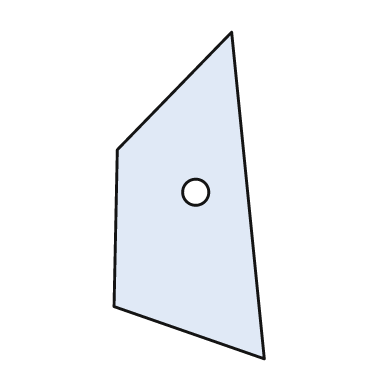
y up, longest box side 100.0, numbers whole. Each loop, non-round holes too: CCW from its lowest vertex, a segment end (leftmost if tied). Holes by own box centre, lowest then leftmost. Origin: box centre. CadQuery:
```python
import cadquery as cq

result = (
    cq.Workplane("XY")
    .moveTo(23.0, -50.0)
    .lineTo(13.0, 50.0)
    .lineTo(-22.0, 14.0)
    .lineTo(-23.0, -34.0)
    .close()
    .moveTo(2.0, 1.0)
    .circle(4.0)
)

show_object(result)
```